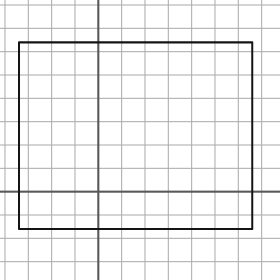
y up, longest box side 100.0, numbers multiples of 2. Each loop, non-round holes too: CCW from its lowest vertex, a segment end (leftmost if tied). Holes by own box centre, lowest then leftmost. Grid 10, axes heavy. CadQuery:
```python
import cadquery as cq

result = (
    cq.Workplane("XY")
    .moveTo(-34.0, -16.0)
    .lineTo(66.0, -16.0)
    .lineTo(66.0, 64.0)
    .lineTo(-34.0, 64.0)
    .close()
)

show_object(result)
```